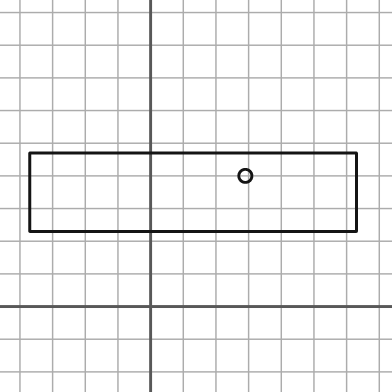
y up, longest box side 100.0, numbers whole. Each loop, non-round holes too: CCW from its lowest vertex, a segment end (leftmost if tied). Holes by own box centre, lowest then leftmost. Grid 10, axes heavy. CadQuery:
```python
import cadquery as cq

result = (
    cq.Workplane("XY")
    .moveTo(-37.0, 23.0)
    .lineTo(63.0, 23.0)
    .lineTo(63.0, 47.0)
    .lineTo(-37.0, 47.0)
    .close()
    .moveTo(29.0, 40.0)
    .circle(2.0)
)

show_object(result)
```